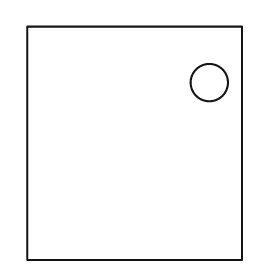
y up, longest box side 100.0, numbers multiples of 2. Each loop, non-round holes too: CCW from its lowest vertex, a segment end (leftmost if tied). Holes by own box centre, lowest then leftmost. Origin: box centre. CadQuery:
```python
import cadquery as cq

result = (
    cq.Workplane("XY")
    .moveTo(-46.0, -50.0)
    .lineTo(46.0, -50.0)
    .lineTo(46.0, 50.0)
    .lineTo(-46.0, 50.0)
    .close()
    .moveTo(32.0, 26.0)
    .circle(8.0)
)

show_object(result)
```